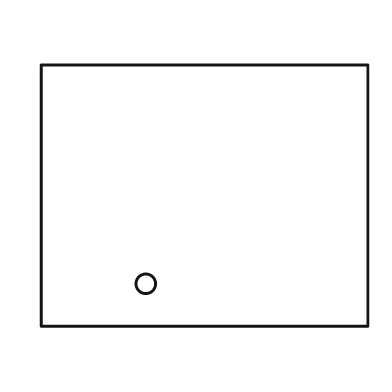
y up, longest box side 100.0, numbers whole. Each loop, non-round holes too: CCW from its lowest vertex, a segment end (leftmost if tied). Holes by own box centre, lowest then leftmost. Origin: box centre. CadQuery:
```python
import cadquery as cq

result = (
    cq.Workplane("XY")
    .moveTo(-50.0, -40.0)
    .lineTo(50.0, -40.0)
    .lineTo(50.0, 40.0)
    .lineTo(-50.0, 40.0)
    .close()
    .moveTo(-18.0, -27.0)
    .circle(3.0)
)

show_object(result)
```